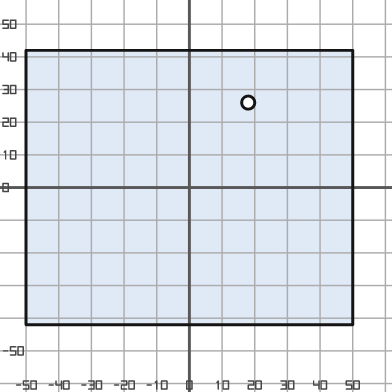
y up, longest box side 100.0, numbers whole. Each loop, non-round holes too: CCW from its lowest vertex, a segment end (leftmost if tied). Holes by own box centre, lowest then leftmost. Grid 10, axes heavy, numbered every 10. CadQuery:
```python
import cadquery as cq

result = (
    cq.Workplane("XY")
    .moveTo(-50.0, -42.0)
    .lineTo(50.0, -42.0)
    .lineTo(50.0, 42.0)
    .lineTo(-50.0, 42.0)
    .close()
    .moveTo(18.0, 26.0)
    .circle(2.0)
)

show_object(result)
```